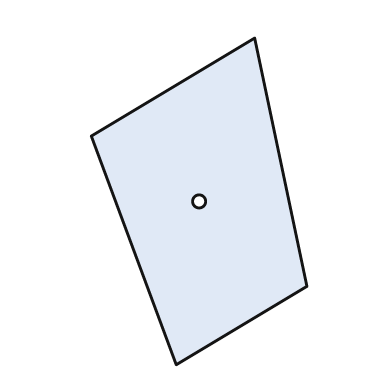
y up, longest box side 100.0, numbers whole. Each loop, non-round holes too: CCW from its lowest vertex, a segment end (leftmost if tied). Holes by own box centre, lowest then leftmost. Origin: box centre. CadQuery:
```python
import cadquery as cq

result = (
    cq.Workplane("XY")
    .moveTo(-7.0, -50.0)
    .lineTo(33.0, -26.0)
    .lineTo(17.0, 50.0)
    .lineTo(-33.0, 20.0)
    .close()
    .moveTo(0.0, 0.0)
    .circle(2.0)
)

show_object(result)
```